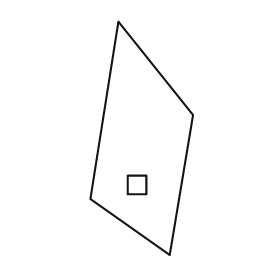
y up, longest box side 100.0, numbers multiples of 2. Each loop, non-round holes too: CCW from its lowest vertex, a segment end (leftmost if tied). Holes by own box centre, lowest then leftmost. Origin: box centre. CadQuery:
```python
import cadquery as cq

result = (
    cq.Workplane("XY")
    .moveTo(12.0, -50.0)
    .lineTo(22.0, 10.0)
    .lineTo(-10.0, 50.0)
    .lineTo(-22.0, -26.0)
    .close()
    .moveTo(-6.0, -24.0)
    .lineTo(2.0, -24.0)
    .lineTo(2.0, -16.0)
    .lineTo(-6.0, -16.0)
    .close()
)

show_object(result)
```